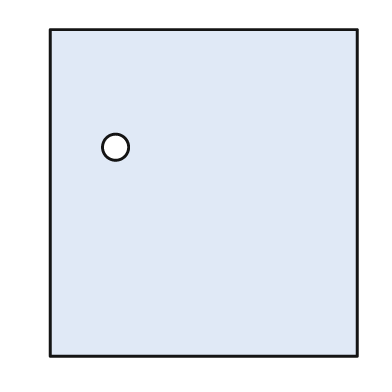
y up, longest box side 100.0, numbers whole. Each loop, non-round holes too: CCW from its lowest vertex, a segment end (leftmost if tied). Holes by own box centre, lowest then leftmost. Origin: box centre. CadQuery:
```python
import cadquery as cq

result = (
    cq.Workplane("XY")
    .moveTo(-47.0, -50.0)
    .lineTo(47.0, -50.0)
    .lineTo(47.0, 50.0)
    .lineTo(-47.0, 50.0)
    .close()
    .moveTo(-27.0, 14.0)
    .circle(4.0)
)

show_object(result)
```